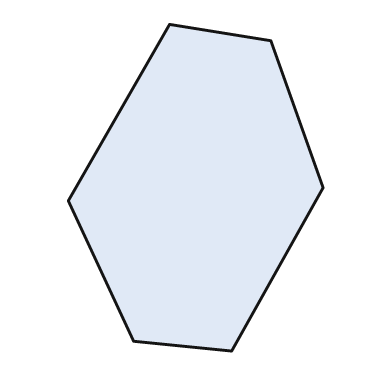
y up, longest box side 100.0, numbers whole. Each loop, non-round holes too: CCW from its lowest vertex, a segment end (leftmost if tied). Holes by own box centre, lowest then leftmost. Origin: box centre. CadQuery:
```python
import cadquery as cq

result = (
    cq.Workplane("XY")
    .moveTo(11.0, -50.0)
    .lineTo(39.0, 0.0)
    .lineTo(23.0, 45.0)
    .lineTo(-8.0, 50.0)
    .lineTo(-39.0, -4.0)
    .lineTo(-19.0, -47.0)
    .close()
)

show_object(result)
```